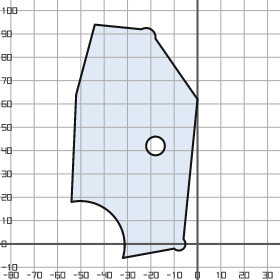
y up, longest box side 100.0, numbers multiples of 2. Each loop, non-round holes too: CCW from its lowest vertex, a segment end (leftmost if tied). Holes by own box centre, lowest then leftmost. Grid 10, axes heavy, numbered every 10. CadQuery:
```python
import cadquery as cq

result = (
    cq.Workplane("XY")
    .moveTo(-32.0, -6.0)
    .lineTo(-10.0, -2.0)
    .threePointArc((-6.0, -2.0), (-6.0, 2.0))
    .lineTo(0.0, 62.0)
    .lineTo(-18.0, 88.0)
    .threePointArc((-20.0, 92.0), (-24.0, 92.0))
    .lineTo(-44.0, 94.0)
    .lineTo(-52.0, 64.0)
    .lineTo(-54.0, 18.0)
    .threePointArc((-36.0, 12.0), (-32.0, -6.0))
    .close()
    .moveTo(-18.0, 42.0)
    .circle(4.0)
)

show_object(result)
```